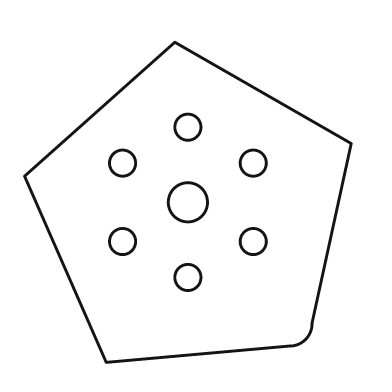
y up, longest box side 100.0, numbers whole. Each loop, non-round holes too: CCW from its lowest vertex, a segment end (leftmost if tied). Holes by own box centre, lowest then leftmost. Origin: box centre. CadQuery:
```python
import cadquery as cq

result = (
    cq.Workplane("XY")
    .moveTo(-25.0, -49.0)
    .lineTo(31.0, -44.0)
    .threePointArc((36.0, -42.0), (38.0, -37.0))
    .lineTo(50.0, 18.0)
    .lineTo(-4.0, 49.0)
    .lineTo(-50.0, 8.0)
    .close()
    .moveTo(0.0, -23.0)
    .circle(4.0)
    .moveTo(-20.0, -12.0)
    .circle(4.0)
    .moveTo(20.0, -12.0)
    .circle(4.0)
    .moveTo(0.0, 0.0)
    .circle(6.0)
    .moveTo(-20.0, 12.0)
    .circle(4.0)
    .moveTo(20.0, 12.0)
    .circle(4.0)
    .moveTo(0.0, 23.0)
    .circle(4.0)
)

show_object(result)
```